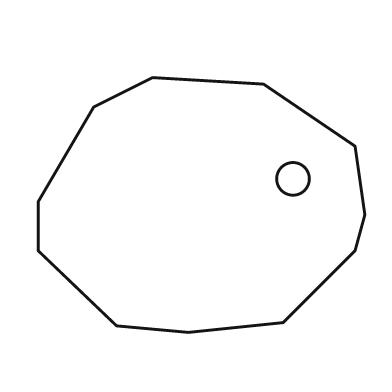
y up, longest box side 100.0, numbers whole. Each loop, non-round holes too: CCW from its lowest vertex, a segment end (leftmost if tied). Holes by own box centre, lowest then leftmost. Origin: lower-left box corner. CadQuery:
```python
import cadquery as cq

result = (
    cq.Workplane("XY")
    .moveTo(46.0, 0.0)
    .lineTo(75.0, 3.0)
    .lineTo(97.0, 25.0)
    .lineTo(100.0, 36.0)
    .lineTo(97.0, 57.0)
    .lineTo(69.0, 76.0)
    .lineTo(35.0, 78.0)
    .lineTo(17.0, 69.0)
    .lineTo(0.0, 40.0)
    .lineTo(0.0, 25.0)
    .lineTo(24.0, 2.0)
    .close()
    .moveTo(78.0, 47.0)
    .circle(5.0)
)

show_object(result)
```